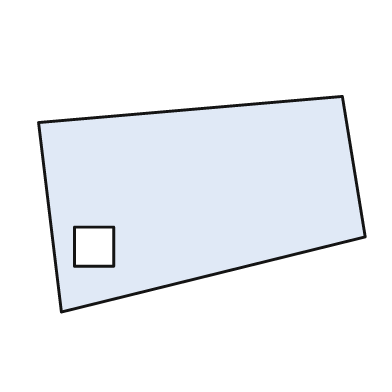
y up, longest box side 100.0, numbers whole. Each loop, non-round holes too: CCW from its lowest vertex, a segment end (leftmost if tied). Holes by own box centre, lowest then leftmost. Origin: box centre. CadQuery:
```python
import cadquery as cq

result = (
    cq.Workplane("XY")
    .moveTo(-43.0, -33.0)
    .lineTo(50.0, -10.0)
    .lineTo(43.0, 33.0)
    .lineTo(-50.0, 25.0)
    .close()
    .moveTo(-39.0, -19.0)
    .lineTo(-27.0, -19.0)
    .lineTo(-27.0, -7.0)
    .lineTo(-39.0, -7.0)
    .close()
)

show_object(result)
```